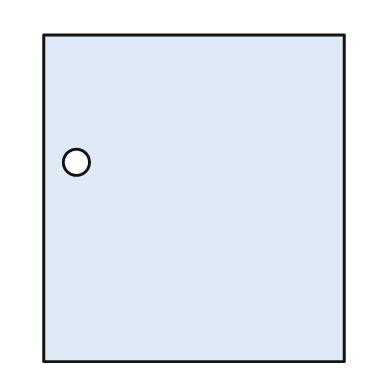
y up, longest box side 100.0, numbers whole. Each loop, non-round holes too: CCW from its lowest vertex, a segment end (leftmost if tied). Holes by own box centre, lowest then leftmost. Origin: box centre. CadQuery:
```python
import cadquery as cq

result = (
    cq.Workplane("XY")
    .moveTo(-46.0, -50.0)
    .lineTo(46.0, -50.0)
    .lineTo(46.0, 50.0)
    .lineTo(-46.0, 50.0)
    .close()
    .moveTo(-36.0, 11.0)
    .circle(4.0)
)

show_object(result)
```